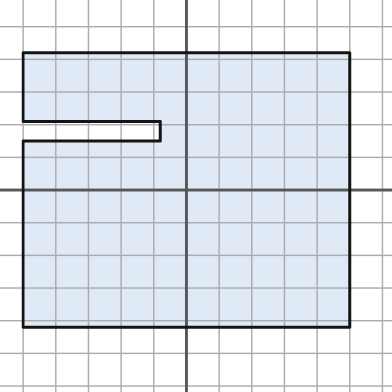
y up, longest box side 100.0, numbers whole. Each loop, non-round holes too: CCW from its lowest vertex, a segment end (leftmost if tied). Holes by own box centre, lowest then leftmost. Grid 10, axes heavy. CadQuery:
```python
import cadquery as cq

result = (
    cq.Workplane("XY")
    .moveTo(-50.0, -42.0)
    .lineTo(50.0, -42.0)
    .lineTo(50.0, 42.0)
    .lineTo(-50.0, 42.0)
    .lineTo(-50.0, 21.0)
    .lineTo(-8.0, 21.0)
    .lineTo(-8.0, 15.0)
    .lineTo(-50.0, 15.0)
    .close()
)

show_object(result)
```